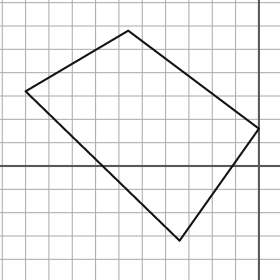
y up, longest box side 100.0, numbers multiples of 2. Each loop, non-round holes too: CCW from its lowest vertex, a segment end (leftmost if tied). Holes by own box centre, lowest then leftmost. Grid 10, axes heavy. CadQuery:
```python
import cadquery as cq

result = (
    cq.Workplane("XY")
    .moveTo(-34.0, -32.0)
    .lineTo(0.0, 16.0)
    .lineTo(-56.0, 58.0)
    .lineTo(-100.0, 32.0)
    .close()
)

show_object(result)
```